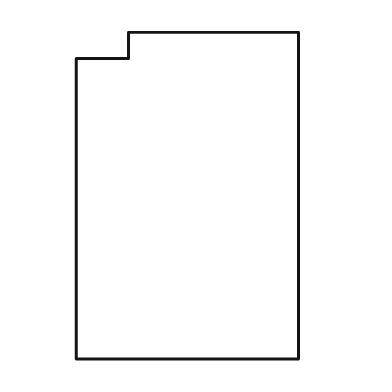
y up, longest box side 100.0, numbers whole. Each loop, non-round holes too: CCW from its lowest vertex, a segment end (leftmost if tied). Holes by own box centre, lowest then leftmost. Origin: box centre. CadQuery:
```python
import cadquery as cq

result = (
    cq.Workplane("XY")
    .moveTo(-34.0, -50.0)
    .lineTo(34.0, -50.0)
    .lineTo(34.0, 50.0)
    .lineTo(-18.0, 50.0)
    .lineTo(-18.0, 42.0)
    .lineTo(-34.0, 42.0)
    .close()
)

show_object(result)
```